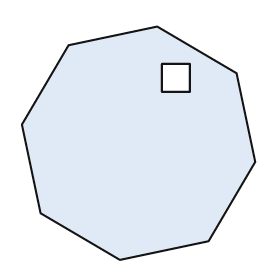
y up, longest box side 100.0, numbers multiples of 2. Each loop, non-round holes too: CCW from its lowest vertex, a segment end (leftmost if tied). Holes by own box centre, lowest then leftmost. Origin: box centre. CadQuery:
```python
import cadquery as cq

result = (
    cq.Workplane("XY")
    .moveTo(-8.0, -50.0)
    .lineTo(30.0, -42.0)
    .lineTo(50.0, -8.0)
    .lineTo(42.0, 30.0)
    .lineTo(8.0, 50.0)
    .lineTo(-30.0, 42.0)
    .lineTo(-50.0, 8.0)
    .lineTo(-42.0, -30.0)
    .close()
    .moveTo(10.0, 22.0)
    .lineTo(22.0, 22.0)
    .lineTo(22.0, 34.0)
    .lineTo(10.0, 34.0)
    .close()
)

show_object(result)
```